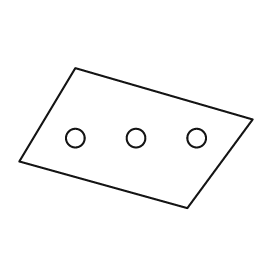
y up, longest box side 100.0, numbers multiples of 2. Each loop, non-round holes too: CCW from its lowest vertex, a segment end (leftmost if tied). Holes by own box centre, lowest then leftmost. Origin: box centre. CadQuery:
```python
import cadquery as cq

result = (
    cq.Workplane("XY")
    .moveTo(22.0, -30.0)
    .lineTo(50.0, 8.0)
    .lineTo(-26.0, 30.0)
    .lineTo(-50.0, -10.0)
    .close()
    .moveTo(-26.0, 0.0)
    .circle(4.0)
    .moveTo(0.0, 0.0)
    .circle(4.0)
    .moveTo(26.0, 0.0)
    .circle(4.0)
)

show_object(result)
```